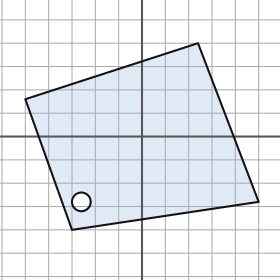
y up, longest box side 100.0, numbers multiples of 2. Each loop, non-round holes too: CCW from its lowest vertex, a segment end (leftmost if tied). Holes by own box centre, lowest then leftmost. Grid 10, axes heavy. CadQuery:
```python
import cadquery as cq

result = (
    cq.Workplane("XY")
    .moveTo(-30.0, -40.0)
    .lineTo(50.0, -28.0)
    .lineTo(24.0, 40.0)
    .lineTo(-50.0, 16.0)
    .close()
    .moveTo(-26.0, -28.0)
    .circle(4.0)
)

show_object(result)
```